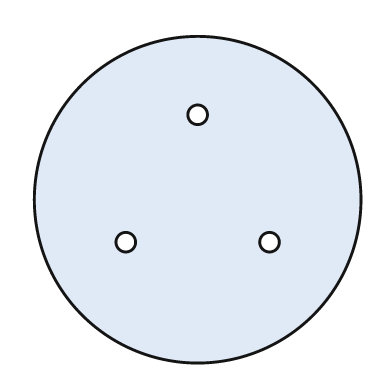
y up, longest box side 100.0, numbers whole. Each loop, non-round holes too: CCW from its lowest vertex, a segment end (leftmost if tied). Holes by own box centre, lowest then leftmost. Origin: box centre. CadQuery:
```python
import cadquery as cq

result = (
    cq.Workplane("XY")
    .moveTo(0.0, 0.0)
    .circle(50.0)
    .moveTo(-22.0, -13.0)
    .circle(3.0)
    .moveTo(22.0, -13.0)
    .circle(3.0)
    .moveTo(0.0, 26.0)
    .circle(3.0)
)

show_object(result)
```